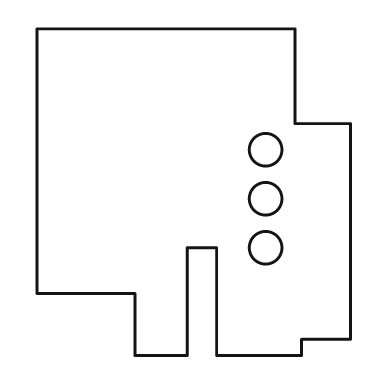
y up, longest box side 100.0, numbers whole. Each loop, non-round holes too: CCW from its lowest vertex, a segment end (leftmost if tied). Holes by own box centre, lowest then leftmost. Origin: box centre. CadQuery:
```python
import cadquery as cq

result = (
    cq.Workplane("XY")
    .moveTo(-18.0, -50.0)
    .lineTo(-2.0, -50.0)
    .lineTo(-2.0, -17.0)
    .lineTo(7.0, -17.0)
    .lineTo(7.0, -50.0)
    .lineTo(33.0, -50.0)
    .lineTo(33.0, -45.0)
    .lineTo(48.0, -45.0)
    .lineTo(48.0, 21.0)
    .lineTo(31.0, 21.0)
    .lineTo(31.0, 50.0)
    .lineTo(-48.0, 50.0)
    .lineTo(-48.0, -31.0)
    .lineTo(-18.0, -31.0)
    .close()
    .moveTo(22.0, -17.0)
    .circle(5.0)
    .moveTo(22.0, -2.0)
    .circle(5.0)
    .moveTo(22.0, 13.0)
    .circle(5.0)
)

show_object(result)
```